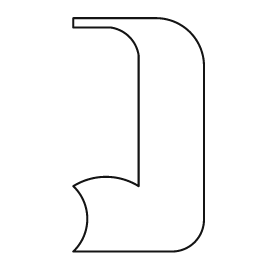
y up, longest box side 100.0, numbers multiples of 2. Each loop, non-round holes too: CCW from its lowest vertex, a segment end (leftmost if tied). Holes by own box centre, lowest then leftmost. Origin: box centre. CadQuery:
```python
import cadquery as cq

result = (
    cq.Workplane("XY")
    .moveTo(-28.0, -50.0)
    .lineTo(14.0, -50.0)
    .threePointArc((24.0, -46.0), (28.0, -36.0))
    .lineTo(28.0, 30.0)
    .threePointArc((22.0, 44.0), (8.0, 50.0))
    .lineTo(-28.0, 50.0)
    .lineTo(-28.0, 46.0)
    .lineTo(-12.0, 46.0)
    .threePointArc((-4.0, 42.0), (0.0, 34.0))
    .lineTo(0.0, -22.0)
    .threePointArc((-14.0, -18.0), (-28.0, -22.0))
    .threePointArc((-22.0, -36.0), (-28.0, -50.0))
    .close()
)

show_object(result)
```